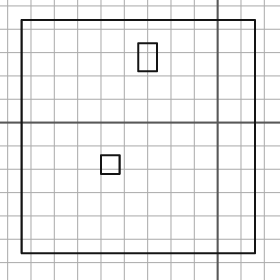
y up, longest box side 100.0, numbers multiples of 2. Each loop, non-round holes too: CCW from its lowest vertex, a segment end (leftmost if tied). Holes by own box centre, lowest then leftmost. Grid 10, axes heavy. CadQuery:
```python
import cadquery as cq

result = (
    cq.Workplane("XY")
    .moveTo(-84.0, -56.0)
    .lineTo(16.0, -56.0)
    .lineTo(16.0, 44.0)
    .lineTo(-84.0, 44.0)
    .close()
    .moveTo(-50.0, -22.0)
    .lineTo(-42.0, -22.0)
    .lineTo(-42.0, -14.0)
    .lineTo(-50.0, -14.0)
    .close()
    .moveTo(-34.0, 22.0)
    .lineTo(-26.0, 22.0)
    .lineTo(-26.0, 34.0)
    .lineTo(-34.0, 34.0)
    .close()
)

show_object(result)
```